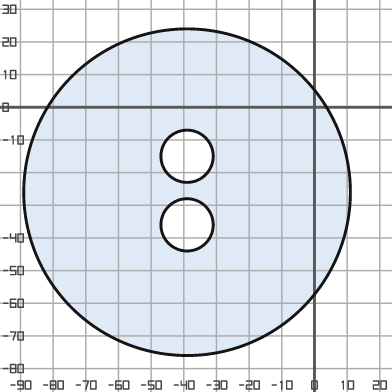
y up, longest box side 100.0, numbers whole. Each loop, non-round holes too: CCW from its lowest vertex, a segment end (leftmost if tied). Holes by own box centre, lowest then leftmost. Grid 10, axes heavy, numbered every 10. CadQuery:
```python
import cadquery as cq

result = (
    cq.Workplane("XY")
    .moveTo(-39.0, -26.0)
    .circle(50.0)
    .moveTo(-39.0, -36.0)
    .circle(8.0)
    .moveTo(-39.0, -15.0)
    .circle(8.0)
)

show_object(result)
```